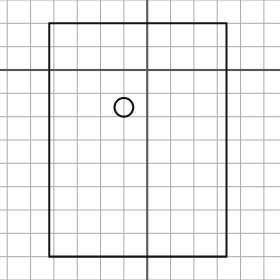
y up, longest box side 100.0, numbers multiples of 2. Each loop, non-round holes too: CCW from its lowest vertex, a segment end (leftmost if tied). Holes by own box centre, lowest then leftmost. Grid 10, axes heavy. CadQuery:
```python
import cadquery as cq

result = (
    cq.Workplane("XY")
    .moveTo(-42.0, -80.0)
    .lineTo(34.0, -80.0)
    .lineTo(34.0, 20.0)
    .lineTo(-42.0, 20.0)
    .close()
    .moveTo(-10.0, -16.0)
    .circle(4.0)
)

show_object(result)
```